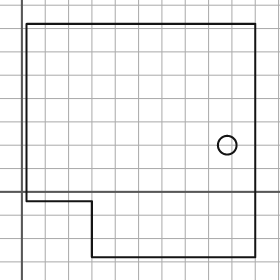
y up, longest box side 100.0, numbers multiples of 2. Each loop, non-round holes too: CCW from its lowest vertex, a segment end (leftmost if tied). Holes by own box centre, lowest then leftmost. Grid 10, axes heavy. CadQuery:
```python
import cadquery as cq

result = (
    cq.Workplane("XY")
    .moveTo(30.0, -28.0)
    .lineTo(100.0, -28.0)
    .lineTo(100.0, 72.0)
    .lineTo(2.0, 72.0)
    .lineTo(2.0, -4.0)
    .lineTo(30.0, -4.0)
    .close()
    .moveTo(88.0, 20.0)
    .circle(4.0)
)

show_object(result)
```